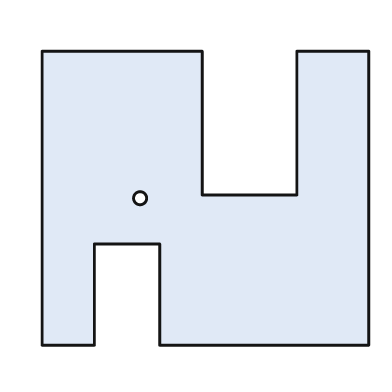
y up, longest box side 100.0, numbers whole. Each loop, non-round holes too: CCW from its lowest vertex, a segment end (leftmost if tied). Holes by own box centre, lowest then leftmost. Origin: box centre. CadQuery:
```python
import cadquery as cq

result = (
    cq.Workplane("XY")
    .moveTo(-50.0, -45.0)
    .lineTo(-34.0, -45.0)
    .lineTo(-34.0, -14.0)
    .lineTo(-14.0, -14.0)
    .lineTo(-14.0, -45.0)
    .lineTo(50.0, -45.0)
    .lineTo(50.0, 45.0)
    .lineTo(28.0, 45.0)
    .lineTo(28.0, 1.0)
    .lineTo(-1.0, 1.0)
    .lineTo(-1.0, 45.0)
    .lineTo(-50.0, 45.0)
    .close()
    .moveTo(-20.0, 0.0)
    .circle(2.0)
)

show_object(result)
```